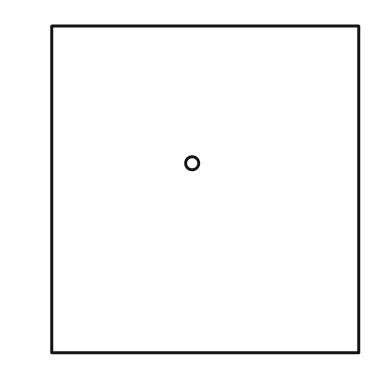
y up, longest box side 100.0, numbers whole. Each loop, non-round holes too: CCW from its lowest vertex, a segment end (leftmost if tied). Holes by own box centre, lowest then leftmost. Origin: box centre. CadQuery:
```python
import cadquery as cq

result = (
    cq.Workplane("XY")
    .moveTo(-47.0, -50.0)
    .lineTo(47.0, -50.0)
    .lineTo(47.0, 50.0)
    .lineTo(-47.0, 50.0)
    .close()
    .moveTo(-4.0, 8.0)
    .circle(2.0)
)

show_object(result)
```